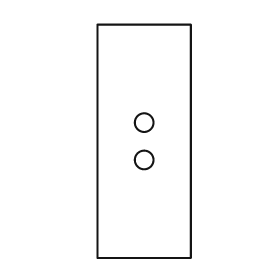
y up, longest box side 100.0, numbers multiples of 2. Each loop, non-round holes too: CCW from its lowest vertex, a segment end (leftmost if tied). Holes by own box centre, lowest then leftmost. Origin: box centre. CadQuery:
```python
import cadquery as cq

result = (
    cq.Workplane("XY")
    .moveTo(-20.0, -50.0)
    .lineTo(20.0, -50.0)
    .lineTo(20.0, 50.0)
    .lineTo(-20.0, 50.0)
    .close()
    .moveTo(0.0, -8.0)
    .circle(4.0)
    .moveTo(0.0, 8.0)
    .circle(4.0)
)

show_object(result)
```